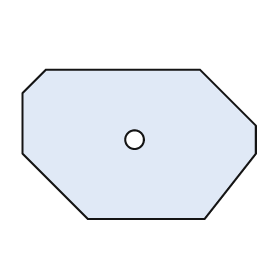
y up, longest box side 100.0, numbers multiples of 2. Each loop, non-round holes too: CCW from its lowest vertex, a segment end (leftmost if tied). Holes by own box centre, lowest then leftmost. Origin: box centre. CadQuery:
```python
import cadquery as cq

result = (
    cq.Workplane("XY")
    .moveTo(-22.0, -32.0)
    .lineTo(28.0, -32.0)
    .lineTo(50.0, -4.0)
    .lineTo(50.0, 8.0)
    .lineTo(26.0, 32.0)
    .lineTo(-40.0, 32.0)
    .lineTo(-50.0, 22.0)
    .lineTo(-50.0, -4.0)
    .close()
    .moveTo(-2.0, 2.0)
    .circle(4.0)
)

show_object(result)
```